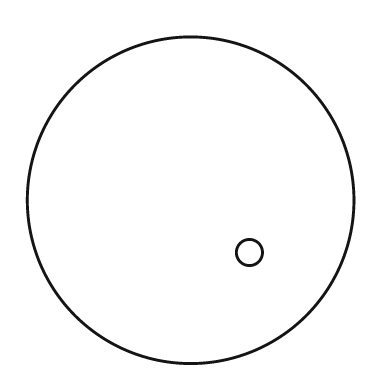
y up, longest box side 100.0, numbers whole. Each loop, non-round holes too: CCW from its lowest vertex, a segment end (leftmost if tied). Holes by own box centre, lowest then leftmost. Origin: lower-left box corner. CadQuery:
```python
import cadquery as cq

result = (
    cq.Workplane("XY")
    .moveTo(50.0, 50.0)
    .circle(50.0)
    .moveTo(68.0, 34.0)
    .circle(4.0)
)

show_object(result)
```